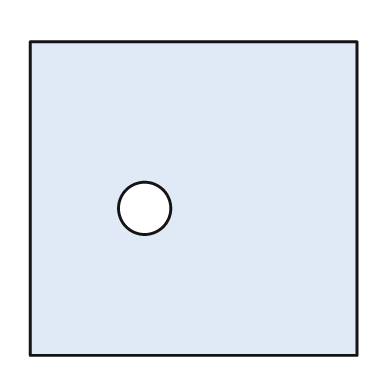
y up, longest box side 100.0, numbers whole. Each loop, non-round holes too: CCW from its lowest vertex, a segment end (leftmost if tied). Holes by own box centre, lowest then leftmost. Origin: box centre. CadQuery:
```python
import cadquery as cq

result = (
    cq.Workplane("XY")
    .moveTo(-50.0, -48.0)
    .lineTo(50.0, -48.0)
    .lineTo(50.0, 48.0)
    .lineTo(-50.0, 48.0)
    .close()
    .moveTo(-15.0, -3.0)
    .circle(8.0)
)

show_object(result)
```